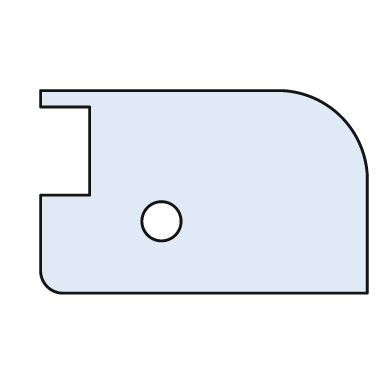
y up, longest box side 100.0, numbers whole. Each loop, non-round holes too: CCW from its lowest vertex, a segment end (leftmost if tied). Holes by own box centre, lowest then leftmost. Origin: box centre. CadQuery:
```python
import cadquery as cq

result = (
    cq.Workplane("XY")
    .moveTo(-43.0, -31.0)
    .lineTo(50.0, -31.0)
    .lineTo(50.0, 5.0)
    .threePointArc((42.0, 23.0), (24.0, 31.0))
    .lineTo(-50.0, 31.0)
    .lineTo(-50.0, 26.0)
    .lineTo(-35.0, 26.0)
    .lineTo(-35.0, -1.0)
    .lineTo(-50.0, -1.0)
    .lineTo(-50.0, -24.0)
    .threePointArc((-48.0, -29.0), (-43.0, -31.0))
    .close()
    .moveTo(-13.0, -9.0)
    .circle(6.0)
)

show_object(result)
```